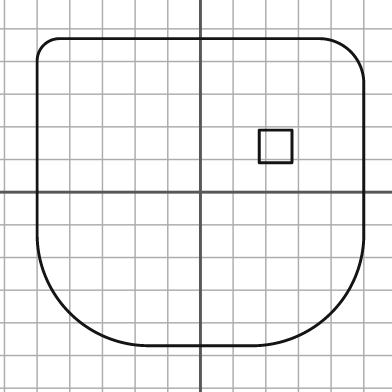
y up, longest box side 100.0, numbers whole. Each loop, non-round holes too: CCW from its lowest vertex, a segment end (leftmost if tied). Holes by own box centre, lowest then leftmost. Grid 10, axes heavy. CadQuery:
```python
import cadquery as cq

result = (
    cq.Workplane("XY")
    .moveTo(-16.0, -47.0)
    .lineTo(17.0, -47.0)
    .threePointArc((40.0, -37.0), (50.0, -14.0))
    .lineTo(50.0, 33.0)
    .threePointArc((46.0, 43.0), (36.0, 47.0))
    .lineTo(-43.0, 47.0)
    .threePointArc((-48.0, 45.0), (-50.0, 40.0))
    .lineTo(-50.0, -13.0)
    .threePointArc((-40.0, -37.0), (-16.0, -47.0))
    .close()
    .moveTo(18.0, 9.0)
    .lineTo(28.0, 9.0)
    .lineTo(28.0, 19.0)
    .lineTo(18.0, 19.0)
    .close()
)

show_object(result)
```